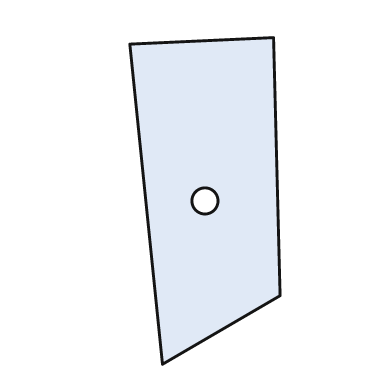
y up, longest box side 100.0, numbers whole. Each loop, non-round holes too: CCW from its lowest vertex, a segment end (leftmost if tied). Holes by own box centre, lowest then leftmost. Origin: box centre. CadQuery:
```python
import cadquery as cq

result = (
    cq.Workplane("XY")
    .moveTo(-13.0, -50.0)
    .lineTo(23.0, -29.0)
    .lineTo(21.0, 50.0)
    .lineTo(-23.0, 48.0)
    .close()
    .moveTo(0.0, 0.0)
    .circle(4.0)
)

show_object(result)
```